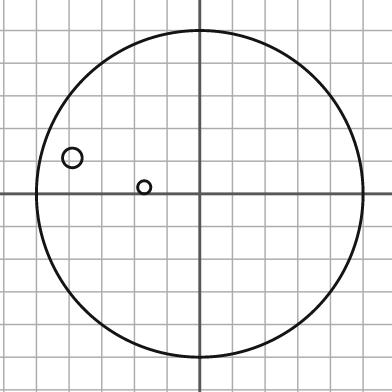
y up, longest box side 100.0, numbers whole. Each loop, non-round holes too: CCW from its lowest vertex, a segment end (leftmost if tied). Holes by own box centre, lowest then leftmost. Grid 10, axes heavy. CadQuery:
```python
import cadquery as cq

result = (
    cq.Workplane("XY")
    .moveTo(0.0, 0.0)
    .circle(50.0)
    .moveTo(-17.0, 2.0)
    .circle(2.0)
    .moveTo(-39.0, 11.0)
    .circle(3.0)
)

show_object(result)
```